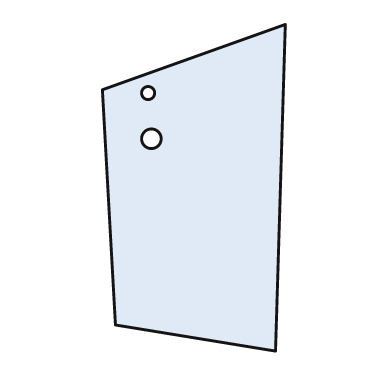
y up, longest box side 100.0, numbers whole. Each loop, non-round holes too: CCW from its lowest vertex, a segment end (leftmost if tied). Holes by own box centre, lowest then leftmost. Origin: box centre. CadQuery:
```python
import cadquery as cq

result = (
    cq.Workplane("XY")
    .moveTo(25.0, -50.0)
    .lineTo(28.0, 50.0)
    .lineTo(-28.0, 30.0)
    .lineTo(-24.0, -42.0)
    .close()
    .moveTo(-13.0, 15.0)
    .circle(3.0)
    .moveTo(-14.0, 29.0)
    .circle(2.0)
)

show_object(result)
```